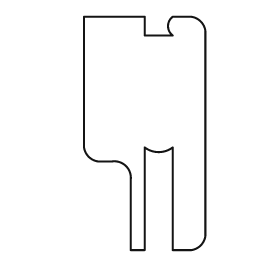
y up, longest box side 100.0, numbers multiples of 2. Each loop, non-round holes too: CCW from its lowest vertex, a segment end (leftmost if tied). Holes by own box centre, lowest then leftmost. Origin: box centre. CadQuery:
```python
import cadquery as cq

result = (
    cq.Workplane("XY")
    .moveTo(-6.0, -50.0)
    .lineTo(0.0, -50.0)
    .lineTo(0.0, -6.0)
    .threePointArc((6.0, -8.0), (12.0, -6.0))
    .lineTo(12.0, -50.0)
    .lineTo(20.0, -50.0)
    .threePointArc((24.0, -48.0), (26.0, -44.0))
    .lineTo(26.0, 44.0)
    .threePointArc((24.0, 48.0), (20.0, 50.0))
    .lineTo(12.0, 50.0)
    .threePointArc((10.0, 46.0), (12.0, 42.0))
    .lineTo(0.0, 42.0)
    .lineTo(0.0, 50.0)
    .lineTo(-26.0, 50.0)
    .lineTo(-26.0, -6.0)
    .threePointArc((-24.0, -10.0), (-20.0, -12.0))
    .lineTo(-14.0, -12.0)
    .threePointArc((-8.0, -14.0), (-6.0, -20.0))
    .close()
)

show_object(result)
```